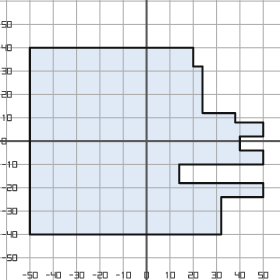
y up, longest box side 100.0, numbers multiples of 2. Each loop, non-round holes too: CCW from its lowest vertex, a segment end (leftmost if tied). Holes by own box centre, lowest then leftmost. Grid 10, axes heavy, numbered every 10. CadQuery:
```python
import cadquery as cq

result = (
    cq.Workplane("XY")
    .moveTo(-50.0, -40.0)
    .lineTo(32.0, -40.0)
    .lineTo(32.0, -24.0)
    .lineTo(50.0, -24.0)
    .lineTo(50.0, -18.0)
    .lineTo(14.0, -18.0)
    .lineTo(14.0, -10.0)
    .lineTo(50.0, -10.0)
    .lineTo(50.0, -4.0)
    .lineTo(40.0, -4.0)
    .lineTo(40.0, 2.0)
    .lineTo(50.0, 2.0)
    .lineTo(50.0, 8.0)
    .lineTo(38.0, 8.0)
    .lineTo(38.0, 12.0)
    .lineTo(24.0, 12.0)
    .lineTo(24.0, 32.0)
    .lineTo(20.0, 32.0)
    .lineTo(20.0, 40.0)
    .lineTo(-50.0, 40.0)
    .close()
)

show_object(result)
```